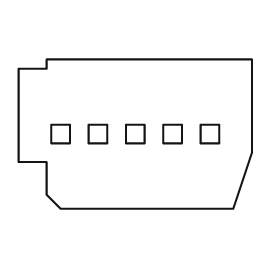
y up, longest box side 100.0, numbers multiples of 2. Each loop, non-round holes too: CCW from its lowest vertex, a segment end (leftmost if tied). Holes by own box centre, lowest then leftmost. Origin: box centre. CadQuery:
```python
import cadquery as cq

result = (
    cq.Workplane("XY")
    .moveTo(-32.0, -32.0)
    .lineTo(42.0, -32.0)
    .lineTo(50.0, -8.0)
    .lineTo(50.0, 32.0)
    .lineTo(-38.0, 32.0)
    .lineTo(-38.0, 28.0)
    .lineTo(-50.0, 28.0)
    .lineTo(-50.0, -12.0)
    .lineTo(-38.0, -12.0)
    .lineTo(-38.0, -26.0)
    .close()
    .moveTo(-36.0, -4.0)
    .lineTo(-28.0, -4.0)
    .lineTo(-28.0, 4.0)
    .lineTo(-36.0, 4.0)
    .close()
    .moveTo(-20.0, -4.0)
    .lineTo(-12.0, -4.0)
    .lineTo(-12.0, 4.0)
    .lineTo(-20.0, 4.0)
    .close()
    .moveTo(-4.0, -4.0)
    .lineTo(4.0, -4.0)
    .lineTo(4.0, 4.0)
    .lineTo(-4.0, 4.0)
    .close()
    .moveTo(12.0, -4.0)
    .lineTo(20.0, -4.0)
    .lineTo(20.0, 4.0)
    .lineTo(12.0, 4.0)
    .close()
    .moveTo(28.0, -4.0)
    .lineTo(36.0, -4.0)
    .lineTo(36.0, 4.0)
    .lineTo(28.0, 4.0)
    .close()
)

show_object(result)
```